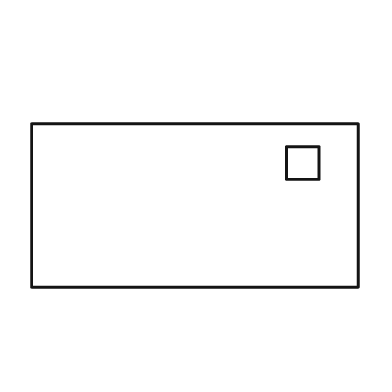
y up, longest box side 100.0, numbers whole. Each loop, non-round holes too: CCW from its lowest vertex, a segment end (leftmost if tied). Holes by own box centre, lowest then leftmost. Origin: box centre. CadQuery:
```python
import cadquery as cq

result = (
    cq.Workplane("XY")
    .moveTo(-50.0, -25.0)
    .lineTo(50.0, -25.0)
    .lineTo(50.0, 25.0)
    .lineTo(-50.0, 25.0)
    .close()
    .moveTo(28.0, 8.0)
    .lineTo(38.0, 8.0)
    .lineTo(38.0, 18.0)
    .lineTo(28.0, 18.0)
    .close()
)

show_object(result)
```